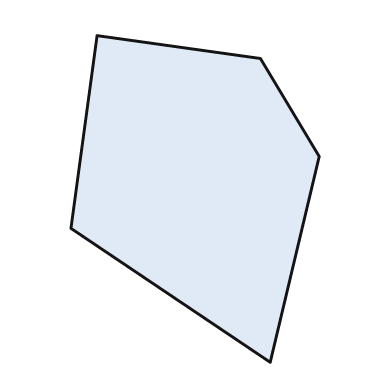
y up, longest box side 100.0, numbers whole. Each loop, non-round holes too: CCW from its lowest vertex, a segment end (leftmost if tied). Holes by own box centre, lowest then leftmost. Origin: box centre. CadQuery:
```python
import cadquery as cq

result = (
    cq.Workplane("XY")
    .moveTo(23.0, -50.0)
    .lineTo(38.0, 13.0)
    .lineTo(20.0, 43.0)
    .lineTo(-30.0, 50.0)
    .lineTo(-38.0, -9.0)
    .close()
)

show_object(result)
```